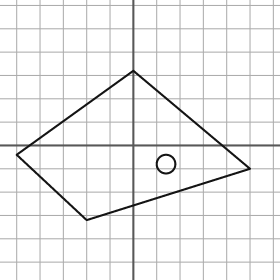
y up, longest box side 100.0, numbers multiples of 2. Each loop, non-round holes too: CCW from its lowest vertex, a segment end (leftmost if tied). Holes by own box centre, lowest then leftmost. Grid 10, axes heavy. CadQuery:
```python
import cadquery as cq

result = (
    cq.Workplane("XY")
    .moveTo(-20.0, -32.0)
    .lineTo(50.0, -10.0)
    .lineTo(0.0, 32.0)
    .lineTo(-50.0, -4.0)
    .close()
    .moveTo(14.0, -8.0)
    .circle(4.0)
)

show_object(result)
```